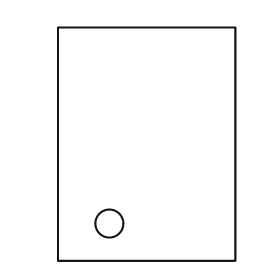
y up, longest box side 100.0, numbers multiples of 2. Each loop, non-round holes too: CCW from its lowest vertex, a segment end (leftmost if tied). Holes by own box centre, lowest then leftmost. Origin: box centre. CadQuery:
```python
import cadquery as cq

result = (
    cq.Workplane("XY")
    .moveTo(-38.0, -50.0)
    .lineTo(38.0, -50.0)
    .lineTo(38.0, 50.0)
    .lineTo(-38.0, 50.0)
    .close()
    .moveTo(-16.0, -34.0)
    .circle(6.0)
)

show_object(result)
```